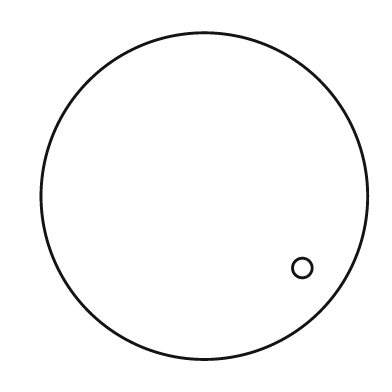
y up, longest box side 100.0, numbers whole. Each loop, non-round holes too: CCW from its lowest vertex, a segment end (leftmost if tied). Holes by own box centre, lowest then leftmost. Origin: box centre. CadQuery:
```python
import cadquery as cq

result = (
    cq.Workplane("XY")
    .moveTo(0.0, 0.0)
    .circle(50.0)
    .moveTo(30.0, -22.0)
    .circle(3.0)
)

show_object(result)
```